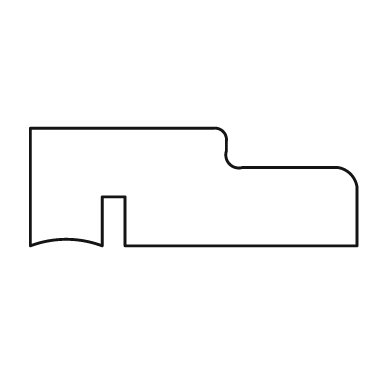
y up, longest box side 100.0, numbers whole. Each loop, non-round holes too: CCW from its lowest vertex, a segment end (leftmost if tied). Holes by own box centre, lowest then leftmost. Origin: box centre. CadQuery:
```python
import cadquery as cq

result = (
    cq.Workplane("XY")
    .moveTo(-50.0, -18.0)
    .threePointArc((-39.0, -16.0), (-28.0, -18.0))
    .lineTo(-28.0, -3.0)
    .lineTo(-21.0, -3.0)
    .lineTo(-21.0, -18.0)
    .lineTo(50.0, -18.0)
    .lineTo(50.0, 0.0)
    .threePointArc((48.0, 4.0), (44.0, 6.0))
    .lineTo(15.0, 6.0)
    .threePointArc((11.0, 7.0), (10.0, 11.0))
    .lineTo(10.0, 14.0)
    .threePointArc((9.0, 17.0), (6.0, 18.0))
    .lineTo(-50.0, 18.0)
    .close()
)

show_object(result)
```